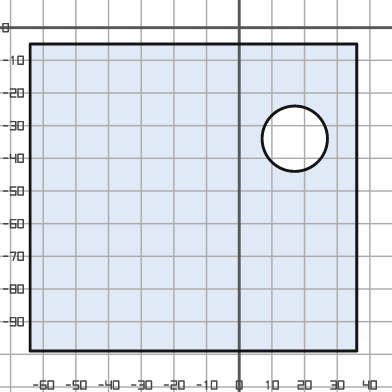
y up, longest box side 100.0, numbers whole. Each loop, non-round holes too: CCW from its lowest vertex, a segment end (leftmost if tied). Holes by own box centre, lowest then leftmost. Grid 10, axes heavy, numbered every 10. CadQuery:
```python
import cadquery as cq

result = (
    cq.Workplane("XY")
    .moveTo(-64.0, -99.0)
    .lineTo(36.0, -99.0)
    .lineTo(36.0, -5.0)
    .lineTo(-64.0, -5.0)
    .close()
    .moveTo(17.0, -34.0)
    .circle(10.0)
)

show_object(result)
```